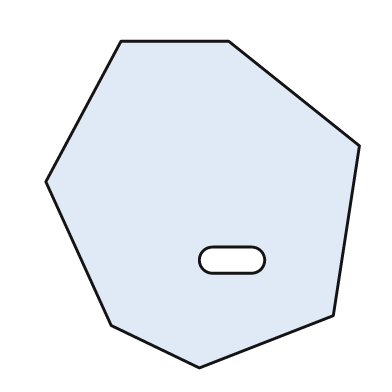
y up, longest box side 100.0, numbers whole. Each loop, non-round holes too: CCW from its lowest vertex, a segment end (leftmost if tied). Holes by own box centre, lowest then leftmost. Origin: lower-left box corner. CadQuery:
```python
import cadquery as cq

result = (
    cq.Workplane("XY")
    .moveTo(47.0, 0.0)
    .lineTo(88.0, 16.0)
    .lineTo(96.0, 68.0)
    .lineTo(56.0, 100.0)
    .lineTo(23.0, 100.0)
    .lineTo(0.0, 57.0)
    .lineTo(20.0, 13.0)
    .close()
    .moveTo(51.0, 29.0)
    .lineTo(63.0, 29.0)
    .threePointArc((67.0, 33.0), (63.0, 37.0))
    .lineTo(51.0, 37.0)
    .threePointArc((47.0, 33.0), (51.0, 29.0))
    .close()
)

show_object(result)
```